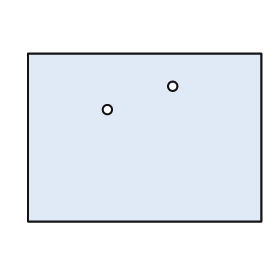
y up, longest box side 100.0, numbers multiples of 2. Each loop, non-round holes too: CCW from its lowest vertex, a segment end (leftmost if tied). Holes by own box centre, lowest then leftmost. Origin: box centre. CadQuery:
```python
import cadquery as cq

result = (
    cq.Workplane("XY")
    .moveTo(-50.0, -36.0)
    .lineTo(50.0, -36.0)
    .lineTo(50.0, 36.0)
    .lineTo(-50.0, 36.0)
    .close()
    .moveTo(-16.0, 12.0)
    .circle(2.0)
    .moveTo(12.0, 22.0)
    .circle(2.0)
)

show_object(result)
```